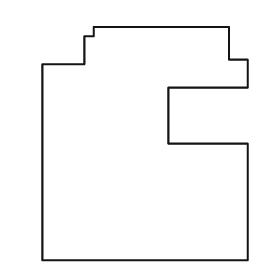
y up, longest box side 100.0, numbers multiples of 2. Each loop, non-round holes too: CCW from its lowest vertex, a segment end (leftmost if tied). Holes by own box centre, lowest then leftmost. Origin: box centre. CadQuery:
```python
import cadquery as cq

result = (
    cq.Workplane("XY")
    .moveTo(-44.0, -50.0)
    .lineTo(44.0, -50.0)
    .lineTo(44.0, 0.0)
    .lineTo(10.0, 0.0)
    .lineTo(10.0, 24.0)
    .lineTo(44.0, 24.0)
    .lineTo(44.0, 36.0)
    .lineTo(36.0, 36.0)
    .lineTo(36.0, 50.0)
    .lineTo(-22.0, 50.0)
    .lineTo(-22.0, 46.0)
    .lineTo(-26.0, 46.0)
    .lineTo(-26.0, 34.0)
    .lineTo(-44.0, 34.0)
    .close()
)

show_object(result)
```